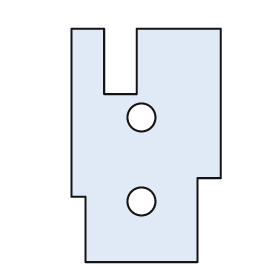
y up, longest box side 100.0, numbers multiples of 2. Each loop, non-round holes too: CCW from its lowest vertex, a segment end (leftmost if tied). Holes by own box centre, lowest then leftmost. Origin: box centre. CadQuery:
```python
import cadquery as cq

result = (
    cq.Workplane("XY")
    .moveTo(-26.0, -50.0)
    .lineTo(22.0, -50.0)
    .lineTo(22.0, -14.0)
    .lineTo(32.0, -14.0)
    .lineTo(32.0, 50.0)
    .lineTo(-4.0, 50.0)
    .lineTo(-4.0, 22.0)
    .lineTo(-18.0, 22.0)
    .lineTo(-18.0, 50.0)
    .lineTo(-32.0, 50.0)
    .lineTo(-32.0, -22.0)
    .lineTo(-26.0, -22.0)
    .close()
    .moveTo(-2.0, -24.0)
    .circle(6.0)
    .moveTo(-2.0, 12.0)
    .circle(6.0)
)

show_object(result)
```